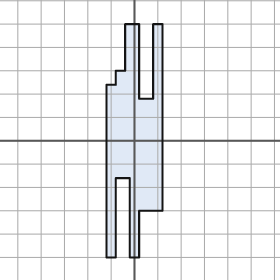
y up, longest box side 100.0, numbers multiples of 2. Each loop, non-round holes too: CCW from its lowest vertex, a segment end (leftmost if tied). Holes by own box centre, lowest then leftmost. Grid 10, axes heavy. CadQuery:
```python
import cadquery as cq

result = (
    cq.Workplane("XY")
    .moveTo(-12.0, -50.0)
    .lineTo(-8.0, -50.0)
    .lineTo(-8.0, -16.0)
    .lineTo(-2.0, -16.0)
    .lineTo(-2.0, -50.0)
    .lineTo(2.0, -50.0)
    .lineTo(2.0, -30.0)
    .lineTo(12.0, -30.0)
    .lineTo(12.0, 50.0)
    .lineTo(8.0, 50.0)
    .lineTo(8.0, 18.0)
    .lineTo(2.0, 18.0)
    .lineTo(2.0, 50.0)
    .lineTo(-4.0, 50.0)
    .lineTo(-4.0, 30.0)
    .lineTo(-8.0, 30.0)
    .lineTo(-8.0, 24.0)
    .lineTo(-12.0, 24.0)
    .close()
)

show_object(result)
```